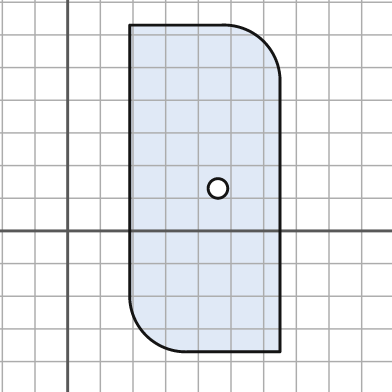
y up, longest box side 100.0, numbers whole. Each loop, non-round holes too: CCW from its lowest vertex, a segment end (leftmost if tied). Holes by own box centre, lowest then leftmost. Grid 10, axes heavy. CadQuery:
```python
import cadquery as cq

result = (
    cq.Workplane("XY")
    .moveTo(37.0, -37.0)
    .lineTo(65.0, -37.0)
    .lineTo(65.0, 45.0)
    .threePointArc((60.0, 58.0), (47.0, 63.0))
    .lineTo(19.0, 63.0)
    .lineTo(19.0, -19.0)
    .threePointArc((24.0, -32.0), (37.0, -37.0))
    .close()
    .moveTo(46.0, 13.0)
    .circle(3.0)
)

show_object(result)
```